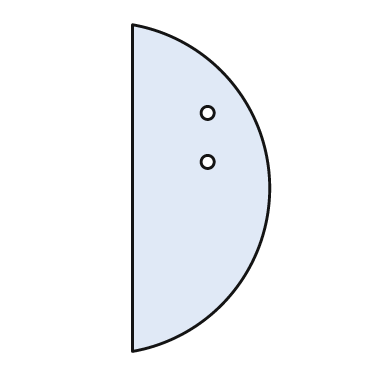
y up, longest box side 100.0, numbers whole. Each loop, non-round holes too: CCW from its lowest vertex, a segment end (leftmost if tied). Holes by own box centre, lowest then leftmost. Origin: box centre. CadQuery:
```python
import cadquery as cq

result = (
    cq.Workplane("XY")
    .moveTo(-21.0, -50.0)
    .threePointArc((21.0, 0.0), (-21.0, 50.0))
    .close()
    .moveTo(2.0, 8.0)
    .circle(2.0)
    .moveTo(2.0, 23.0)
    .circle(2.0)
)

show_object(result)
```